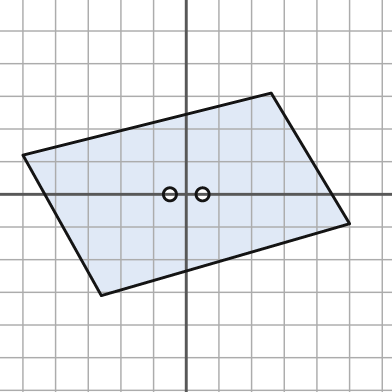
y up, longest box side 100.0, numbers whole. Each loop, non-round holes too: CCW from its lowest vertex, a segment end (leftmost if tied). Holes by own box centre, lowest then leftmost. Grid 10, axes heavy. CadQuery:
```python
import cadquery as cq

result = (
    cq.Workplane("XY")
    .moveTo(-26.0, -31.0)
    .lineTo(50.0, -9.0)
    .lineTo(26.0, 31.0)
    .lineTo(-50.0, 12.0)
    .close()
    .moveTo(-5.0, 0.0)
    .circle(2.0)
    .moveTo(5.0, 0.0)
    .circle(2.0)
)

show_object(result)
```